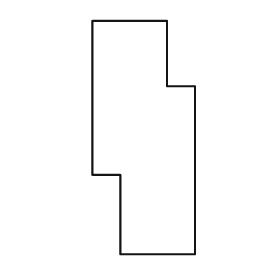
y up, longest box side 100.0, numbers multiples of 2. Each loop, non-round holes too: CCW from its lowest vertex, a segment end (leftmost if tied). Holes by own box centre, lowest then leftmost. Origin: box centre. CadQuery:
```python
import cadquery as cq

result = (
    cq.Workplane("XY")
    .moveTo(-10.0, -50.0)
    .lineTo(22.0, -50.0)
    .lineTo(22.0, 22.0)
    .lineTo(10.0, 22.0)
    .lineTo(10.0, 50.0)
    .lineTo(-22.0, 50.0)
    .lineTo(-22.0, -16.0)
    .lineTo(-10.0, -16.0)
    .close()
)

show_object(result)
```